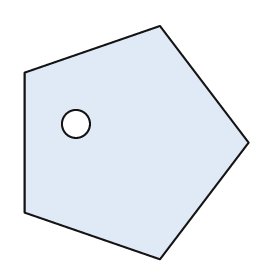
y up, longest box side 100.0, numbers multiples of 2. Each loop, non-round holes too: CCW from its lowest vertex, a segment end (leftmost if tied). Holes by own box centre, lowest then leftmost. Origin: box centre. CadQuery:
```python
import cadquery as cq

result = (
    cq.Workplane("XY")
    .moveTo(10.0, -50.0)
    .lineTo(48.0, 0.0)
    .lineTo(10.0, 50.0)
    .lineTo(-48.0, 30.0)
    .lineTo(-48.0, -30.0)
    .close()
    .moveTo(-26.0, 8.0)
    .circle(6.0)
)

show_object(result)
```